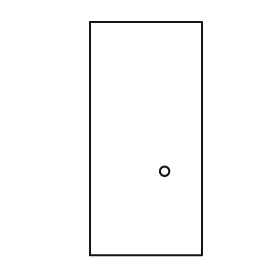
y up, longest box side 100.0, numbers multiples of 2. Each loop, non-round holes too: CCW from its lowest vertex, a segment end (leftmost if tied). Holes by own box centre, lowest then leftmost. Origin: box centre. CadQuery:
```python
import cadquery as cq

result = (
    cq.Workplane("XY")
    .moveTo(-24.0, -50.0)
    .lineTo(24.0, -50.0)
    .lineTo(24.0, 50.0)
    .lineTo(-24.0, 50.0)
    .close()
    .moveTo(8.0, -14.0)
    .circle(2.0)
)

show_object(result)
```